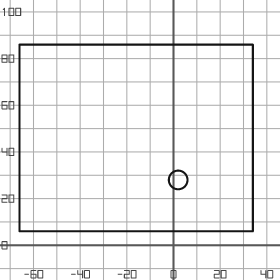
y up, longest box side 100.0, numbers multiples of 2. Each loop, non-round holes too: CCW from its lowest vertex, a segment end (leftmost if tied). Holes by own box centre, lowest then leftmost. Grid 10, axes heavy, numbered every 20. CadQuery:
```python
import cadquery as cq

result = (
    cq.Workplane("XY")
    .moveTo(-66.0, 6.0)
    .lineTo(34.0, 6.0)
    .lineTo(34.0, 86.0)
    .lineTo(-66.0, 86.0)
    .close()
    .moveTo(2.0, 28.0)
    .circle(4.0)
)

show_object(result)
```